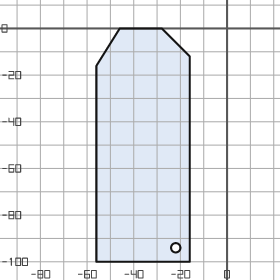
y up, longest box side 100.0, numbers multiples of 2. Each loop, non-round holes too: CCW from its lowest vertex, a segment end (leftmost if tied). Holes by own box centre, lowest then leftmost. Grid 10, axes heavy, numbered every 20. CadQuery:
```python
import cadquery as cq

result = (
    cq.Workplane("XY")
    .moveTo(-56.0, -100.0)
    .lineTo(-16.0, -100.0)
    .lineTo(-16.0, -12.0)
    .lineTo(-28.0, 0.0)
    .lineTo(-46.0, 0.0)
    .lineTo(-56.0, -16.0)
    .close()
    .moveTo(-22.0, -94.0)
    .circle(2.0)
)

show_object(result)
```